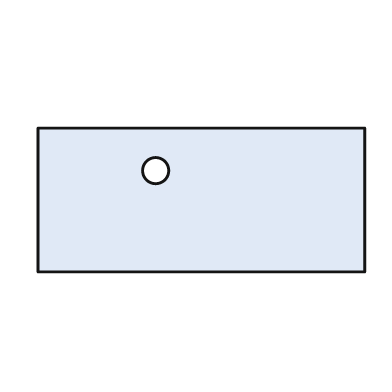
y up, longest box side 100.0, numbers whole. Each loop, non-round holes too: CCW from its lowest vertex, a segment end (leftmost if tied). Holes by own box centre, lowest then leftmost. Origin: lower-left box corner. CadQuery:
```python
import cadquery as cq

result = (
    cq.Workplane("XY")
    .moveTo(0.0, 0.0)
    .lineTo(100.0, 0.0)
    .lineTo(100.0, 44.0)
    .lineTo(0.0, 44.0)
    .close()
    .moveTo(36.0, 31.0)
    .circle(4.0)
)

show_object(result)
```